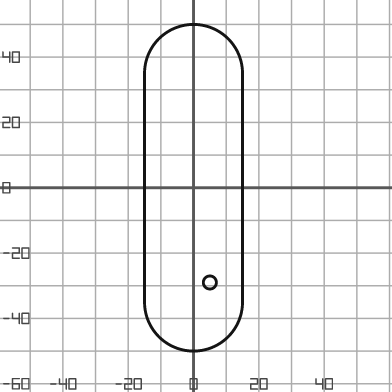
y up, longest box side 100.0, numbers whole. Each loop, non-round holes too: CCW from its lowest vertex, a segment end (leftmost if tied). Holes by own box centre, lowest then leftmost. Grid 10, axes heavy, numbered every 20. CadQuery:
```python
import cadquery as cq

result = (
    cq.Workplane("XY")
    .moveTo(-15.0, -35.0)
    .threePointArc((0.0, -50.0), (15.0, -35.0))
    .lineTo(15.0, 35.0)
    .threePointArc((0.0, 50.0), (-15.0, 35.0))
    .close()
    .moveTo(5.0, -29.0)
    .circle(2.0)
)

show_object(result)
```